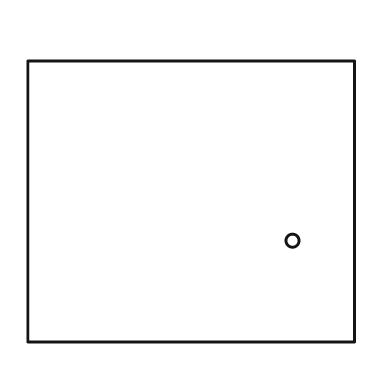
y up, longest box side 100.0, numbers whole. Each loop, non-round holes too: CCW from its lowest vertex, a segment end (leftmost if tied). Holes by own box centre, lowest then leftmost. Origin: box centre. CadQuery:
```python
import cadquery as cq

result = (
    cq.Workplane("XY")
    .moveTo(-50.0, -43.0)
    .lineTo(50.0, -43.0)
    .lineTo(50.0, 43.0)
    .lineTo(-50.0, 43.0)
    .close()
    .moveTo(31.0, -12.0)
    .circle(2.0)
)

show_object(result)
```